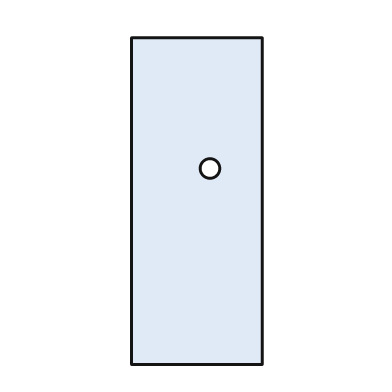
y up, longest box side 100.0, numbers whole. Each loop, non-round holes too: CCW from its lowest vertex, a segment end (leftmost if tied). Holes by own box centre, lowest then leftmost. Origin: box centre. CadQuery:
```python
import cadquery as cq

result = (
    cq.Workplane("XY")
    .moveTo(-20.0, -50.0)
    .lineTo(20.0, -50.0)
    .lineTo(20.0, 50.0)
    .lineTo(-20.0, 50.0)
    .close()
    .moveTo(4.0, 10.0)
    .circle(3.0)
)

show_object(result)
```